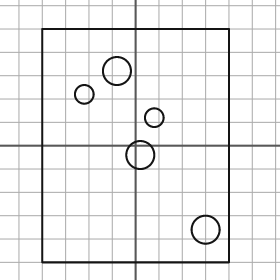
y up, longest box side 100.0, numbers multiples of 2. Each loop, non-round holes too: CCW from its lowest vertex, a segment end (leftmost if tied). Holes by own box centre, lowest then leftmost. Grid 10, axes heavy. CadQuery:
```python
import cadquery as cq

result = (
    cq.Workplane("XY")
    .moveTo(-40.0, -50.0)
    .lineTo(40.0, -50.0)
    .lineTo(40.0, 50.0)
    .lineTo(-40.0, 50.0)
    .close()
    .moveTo(30.0, -36.0)
    .circle(6.0)
    .moveTo(2.0, -4.0)
    .circle(6.0)
    .moveTo(8.0, 12.0)
    .circle(4.0)
    .moveTo(-22.0, 22.0)
    .circle(4.0)
    .moveTo(-8.0, 32.0)
    .circle(6.0)
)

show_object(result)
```